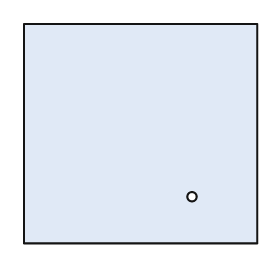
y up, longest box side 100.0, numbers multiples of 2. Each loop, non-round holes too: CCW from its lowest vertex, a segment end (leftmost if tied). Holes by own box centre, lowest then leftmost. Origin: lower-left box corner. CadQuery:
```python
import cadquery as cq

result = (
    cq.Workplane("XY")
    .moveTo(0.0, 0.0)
    .lineTo(100.0, 0.0)
    .lineTo(100.0, 94.0)
    .lineTo(0.0, 94.0)
    .close()
    .moveTo(72.0, 20.0)
    .circle(2.0)
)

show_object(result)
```